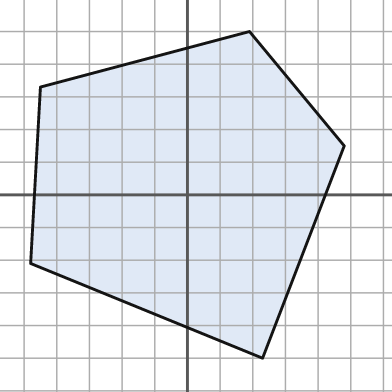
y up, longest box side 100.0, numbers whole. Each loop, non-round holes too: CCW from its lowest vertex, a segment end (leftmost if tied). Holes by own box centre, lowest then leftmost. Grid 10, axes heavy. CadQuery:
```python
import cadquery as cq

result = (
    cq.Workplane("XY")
    .moveTo(23.0, -50.0)
    .lineTo(48.0, 15.0)
    .lineTo(19.0, 50.0)
    .lineTo(-45.0, 33.0)
    .lineTo(-48.0, -21.0)
    .close()
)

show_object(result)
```